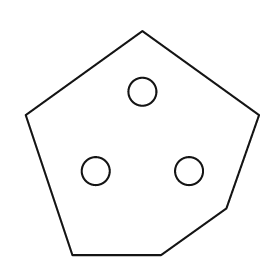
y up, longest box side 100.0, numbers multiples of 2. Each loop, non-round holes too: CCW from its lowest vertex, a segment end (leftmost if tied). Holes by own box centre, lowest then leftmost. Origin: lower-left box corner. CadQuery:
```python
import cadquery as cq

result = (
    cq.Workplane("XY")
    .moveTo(20.0, 0.0)
    .lineTo(58.0, 0.0)
    .lineTo(86.0, 20.0)
    .lineTo(100.0, 60.0)
    .lineTo(50.0, 96.0)
    .lineTo(0.0, 60.0)
    .close()
    .moveTo(30.0, 36.0)
    .circle(6.0)
    .moveTo(70.0, 36.0)
    .circle(6.0)
    .moveTo(50.0, 70.0)
    .circle(6.0)
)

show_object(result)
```